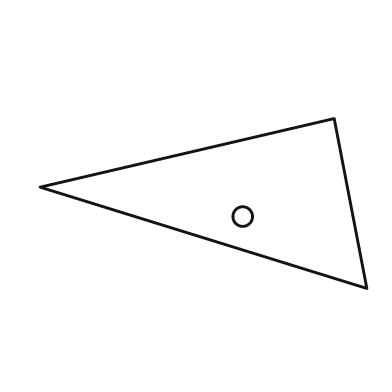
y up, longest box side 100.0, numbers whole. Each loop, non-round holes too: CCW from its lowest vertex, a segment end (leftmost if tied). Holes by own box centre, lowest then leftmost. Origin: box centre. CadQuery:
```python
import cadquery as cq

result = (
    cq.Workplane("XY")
    .moveTo(50.0, -26.0)
    .lineTo(40.0, 26.0)
    .lineTo(-50.0, 5.0)
    .close()
    .moveTo(12.0, -4.0)
    .circle(3.0)
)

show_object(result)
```